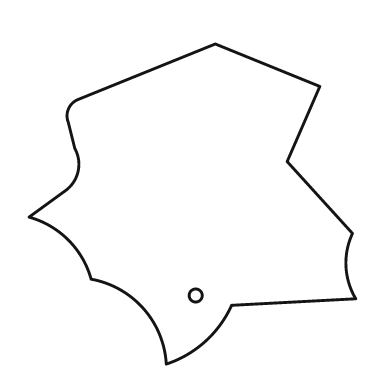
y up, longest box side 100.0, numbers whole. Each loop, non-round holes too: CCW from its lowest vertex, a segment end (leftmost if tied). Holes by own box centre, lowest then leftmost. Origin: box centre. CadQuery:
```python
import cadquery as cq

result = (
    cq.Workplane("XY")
    .moveTo(-8.0, -49.0)
    .threePointArc((4.0, -42.0), (12.0, -31.0))
    .lineTo(50.0, -29.0)
    .threePointArc((47.0, -19.0), (49.0, -9.0))
    .lineTo(29.0, 13.0)
    .lineTo(39.0, 36.0)
    .lineTo(7.0, 49.0)
    .lineTo(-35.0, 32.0)
    .threePointArc((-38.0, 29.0), (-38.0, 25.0))
    .lineTo(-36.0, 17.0)
    .threePointArc((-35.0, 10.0), (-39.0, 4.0))
    .lineTo(-50.0, -4.0)
    .threePointArc((-38.0, -11.0), (-31.0, -23.0))
    .threePointArc((-15.0, -32.0), (-8.0, -49.0))
    .close()
    .moveTo(1.0, -28.0)
    .circle(2.0)
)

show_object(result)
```